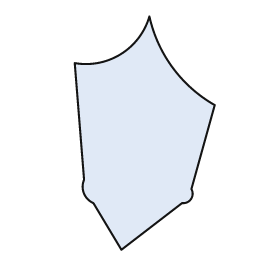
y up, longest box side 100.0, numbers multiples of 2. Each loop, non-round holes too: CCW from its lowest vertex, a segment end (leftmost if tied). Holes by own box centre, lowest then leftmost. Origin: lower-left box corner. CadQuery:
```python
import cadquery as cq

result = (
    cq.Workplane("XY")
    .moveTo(20.0, 0.0)
    .lineTo(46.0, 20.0)
    .threePointArc((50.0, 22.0), (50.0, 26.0))
    .lineTo(60.0, 62.0)
    .threePointArc((42.0, 78.0), (32.0, 100.0))
    .threePointArc((20.0, 84.0), (0.0, 80.0))
    .lineTo(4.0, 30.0)
    .threePointArc((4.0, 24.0), (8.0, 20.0))
    .close()
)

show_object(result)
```